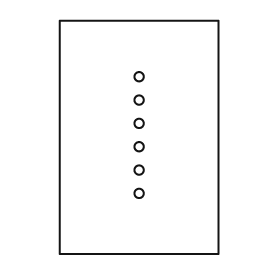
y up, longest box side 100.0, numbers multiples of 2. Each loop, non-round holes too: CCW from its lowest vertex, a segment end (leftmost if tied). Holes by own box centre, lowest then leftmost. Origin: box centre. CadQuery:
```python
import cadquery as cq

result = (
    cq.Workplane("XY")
    .moveTo(-34.0, -50.0)
    .lineTo(34.0, -50.0)
    .lineTo(34.0, 50.0)
    .lineTo(-34.0, 50.0)
    .close()
    .moveTo(0.0, -24.0)
    .circle(2.0)
    .moveTo(0.0, -14.0)
    .circle(2.0)
    .moveTo(0.0, -4.0)
    .circle(2.0)
    .moveTo(0.0, 6.0)
    .circle(2.0)
    .moveTo(0.0, 16.0)
    .circle(2.0)
    .moveTo(0.0, 26.0)
    .circle(2.0)
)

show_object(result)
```